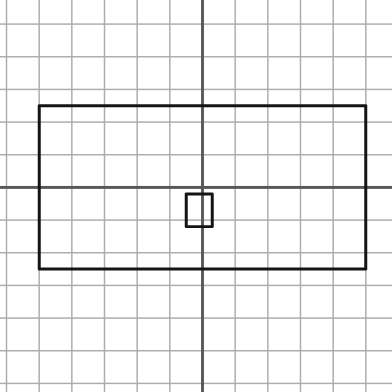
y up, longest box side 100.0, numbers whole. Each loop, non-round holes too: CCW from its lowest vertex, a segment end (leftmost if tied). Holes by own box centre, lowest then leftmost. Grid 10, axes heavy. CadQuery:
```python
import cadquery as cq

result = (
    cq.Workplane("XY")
    .moveTo(-50.0, -25.0)
    .lineTo(50.0, -25.0)
    .lineTo(50.0, 25.0)
    .lineTo(-50.0, 25.0)
    .close()
    .moveTo(-5.0, -12.0)
    .lineTo(3.0, -12.0)
    .lineTo(3.0, -2.0)
    .lineTo(-5.0, -2.0)
    .close()
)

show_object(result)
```